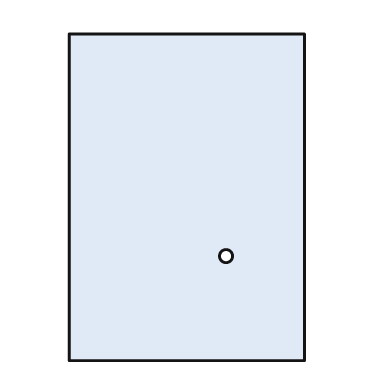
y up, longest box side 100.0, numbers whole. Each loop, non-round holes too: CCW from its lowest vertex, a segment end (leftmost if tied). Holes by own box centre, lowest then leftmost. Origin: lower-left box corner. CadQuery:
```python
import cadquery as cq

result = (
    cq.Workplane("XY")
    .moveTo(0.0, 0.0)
    .lineTo(72.0, 0.0)
    .lineTo(72.0, 100.0)
    .lineTo(0.0, 100.0)
    .close()
    .moveTo(48.0, 32.0)
    .circle(2.0)
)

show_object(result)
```